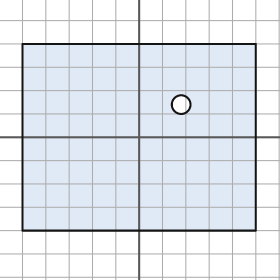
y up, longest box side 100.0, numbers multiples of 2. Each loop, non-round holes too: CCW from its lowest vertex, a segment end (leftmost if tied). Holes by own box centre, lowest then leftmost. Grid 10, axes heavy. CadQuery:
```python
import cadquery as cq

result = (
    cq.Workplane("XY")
    .moveTo(-50.0, -40.0)
    .lineTo(50.0, -40.0)
    .lineTo(50.0, 40.0)
    .lineTo(-50.0, 40.0)
    .close()
    .moveTo(18.0, 14.0)
    .circle(4.0)
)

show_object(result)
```